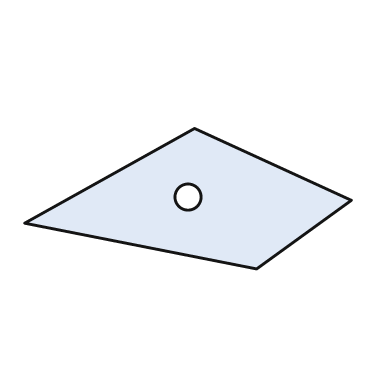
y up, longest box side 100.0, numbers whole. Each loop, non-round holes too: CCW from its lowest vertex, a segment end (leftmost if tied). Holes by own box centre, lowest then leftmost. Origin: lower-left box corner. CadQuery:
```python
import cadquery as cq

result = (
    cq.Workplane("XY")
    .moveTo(71.0, 0.0)
    .lineTo(100.0, 21.0)
    .lineTo(52.0, 43.0)
    .lineTo(0.0, 14.0)
    .close()
    .moveTo(50.0, 22.0)
    .circle(4.0)
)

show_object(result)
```